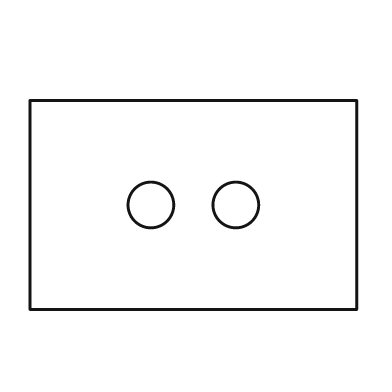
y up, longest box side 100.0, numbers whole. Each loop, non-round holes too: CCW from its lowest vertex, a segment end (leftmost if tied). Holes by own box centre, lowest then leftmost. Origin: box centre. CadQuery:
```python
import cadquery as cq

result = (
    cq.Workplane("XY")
    .moveTo(-50.0, -32.0)
    .lineTo(50.0, -32.0)
    .lineTo(50.0, 32.0)
    .lineTo(-50.0, 32.0)
    .close()
    .moveTo(-13.0, 0.0)
    .circle(7.0)
    .moveTo(13.0, 0.0)
    .circle(7.0)
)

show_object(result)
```